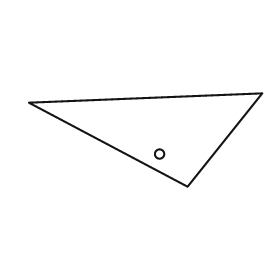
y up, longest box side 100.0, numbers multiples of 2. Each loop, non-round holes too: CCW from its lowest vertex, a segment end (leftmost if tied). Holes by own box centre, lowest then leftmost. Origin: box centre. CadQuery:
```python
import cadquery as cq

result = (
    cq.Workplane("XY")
    .moveTo(18.0, -20.0)
    .lineTo(50.0, 20.0)
    .lineTo(-50.0, 16.0)
    .close()
    .moveTo(6.0, -6.0)
    .circle(2.0)
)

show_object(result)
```